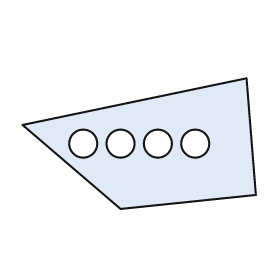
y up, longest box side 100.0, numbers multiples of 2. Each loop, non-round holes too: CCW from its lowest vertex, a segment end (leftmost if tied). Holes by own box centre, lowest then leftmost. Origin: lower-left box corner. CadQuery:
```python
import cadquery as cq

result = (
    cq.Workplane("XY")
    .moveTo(42.0, 0.0)
    .lineTo(100.0, 6.0)
    .lineTo(96.0, 56.0)
    .lineTo(0.0, 36.0)
    .close()
    .moveTo(26.0, 28.0)
    .circle(6.0)
    .moveTo(42.0, 28.0)
    .circle(6.0)
    .moveTo(58.0, 28.0)
    .circle(6.0)
    .moveTo(74.0, 28.0)
    .circle(6.0)
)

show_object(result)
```